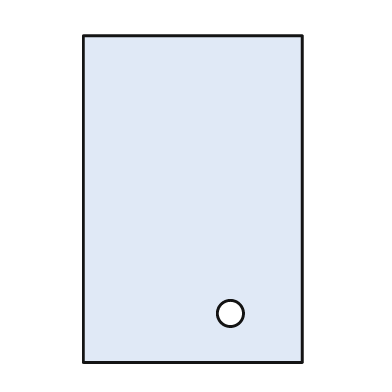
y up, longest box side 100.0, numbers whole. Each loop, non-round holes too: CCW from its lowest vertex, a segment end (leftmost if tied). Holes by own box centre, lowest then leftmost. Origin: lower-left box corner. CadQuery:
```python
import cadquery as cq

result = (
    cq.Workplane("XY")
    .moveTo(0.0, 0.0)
    .lineTo(67.0, 0.0)
    .lineTo(67.0, 100.0)
    .lineTo(0.0, 100.0)
    .close()
    .moveTo(45.0, 15.0)
    .circle(4.0)
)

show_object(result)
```